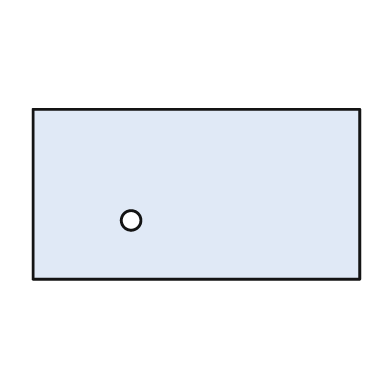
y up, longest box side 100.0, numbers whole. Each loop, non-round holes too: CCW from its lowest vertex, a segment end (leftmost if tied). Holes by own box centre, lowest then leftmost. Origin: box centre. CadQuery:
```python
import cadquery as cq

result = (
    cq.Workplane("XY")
    .moveTo(-50.0, -26.0)
    .lineTo(50.0, -26.0)
    .lineTo(50.0, 26.0)
    .lineTo(-50.0, 26.0)
    .close()
    .moveTo(-20.0, -8.0)
    .circle(3.0)
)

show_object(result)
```